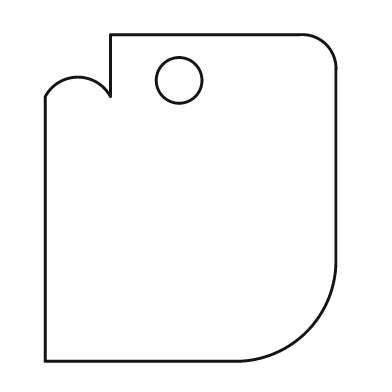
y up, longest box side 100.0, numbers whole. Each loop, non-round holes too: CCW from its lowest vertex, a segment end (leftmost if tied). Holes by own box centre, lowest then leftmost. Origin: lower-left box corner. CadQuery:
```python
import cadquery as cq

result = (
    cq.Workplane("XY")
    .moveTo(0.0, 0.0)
    .lineTo(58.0, 0.0)
    .threePointArc((80.0, 9.0), (89.0, 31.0))
    .lineTo(89.0, 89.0)
    .threePointArc((86.0, 97.0), (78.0, 100.0))
    .lineTo(20.0, 100.0)
    .lineTo(20.0, 81.0)
    .threePointArc((10.0, 87.0), (0.0, 81.0))
    .close()
    .moveTo(41.0, 86.0)
    .circle(7.0)
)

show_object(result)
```